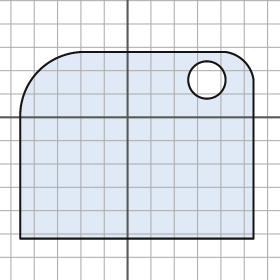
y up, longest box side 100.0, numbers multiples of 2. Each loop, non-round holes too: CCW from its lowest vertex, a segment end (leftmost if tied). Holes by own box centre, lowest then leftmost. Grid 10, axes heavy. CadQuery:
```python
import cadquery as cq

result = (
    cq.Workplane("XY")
    .moveTo(-46.0, -52.0)
    .lineTo(54.0, -52.0)
    .lineTo(54.0, 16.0)
    .threePointArc((50.0, 24.0), (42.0, 28.0))
    .lineTo(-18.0, 28.0)
    .threePointArc((-38.0, 20.0), (-46.0, 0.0))
    .close()
    .moveTo(34.0, 16.0)
    .circle(8.0)
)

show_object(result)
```